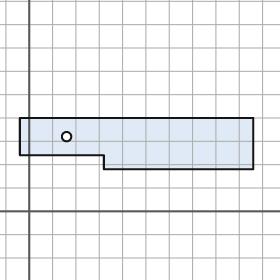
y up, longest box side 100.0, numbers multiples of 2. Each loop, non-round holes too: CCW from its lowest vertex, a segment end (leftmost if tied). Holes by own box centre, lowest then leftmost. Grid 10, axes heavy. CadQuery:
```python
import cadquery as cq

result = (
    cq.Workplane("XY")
    .moveTo(32.0, 18.0)
    .lineTo(96.0, 18.0)
    .lineTo(96.0, 40.0)
    .lineTo(-4.0, 40.0)
    .lineTo(-4.0, 24.0)
    .lineTo(32.0, 24.0)
    .close()
    .moveTo(16.0, 32.0)
    .circle(2.0)
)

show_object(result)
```